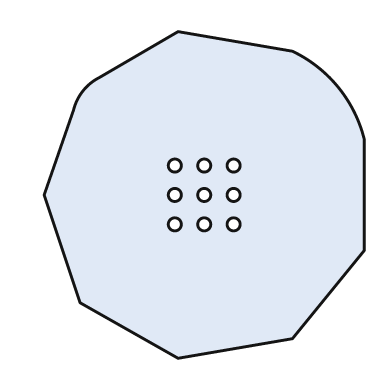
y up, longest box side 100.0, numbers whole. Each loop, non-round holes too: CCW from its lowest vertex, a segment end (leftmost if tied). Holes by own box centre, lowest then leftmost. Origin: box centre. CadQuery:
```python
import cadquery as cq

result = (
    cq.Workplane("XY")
    .moveTo(-8.0, -50.0)
    .lineTo(27.0, -44.0)
    .lineTo(49.0, -17.0)
    .lineTo(49.0, 17.0)
    .threePointArc((41.0, 33.0), (27.0, 44.0))
    .lineTo(-8.0, 50.0)
    .lineTo(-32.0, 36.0)
    .threePointArc((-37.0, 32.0), (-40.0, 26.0))
    .lineTo(-49.0, 0.0)
    .lineTo(-38.0, -33.0)
    .close()
    .moveTo(-9.0, -9.0)
    .circle(2.0)
    .moveTo(0.0, -9.0)
    .circle(2.0)
    .moveTo(9.0, -9.0)
    .circle(2.0)
    .moveTo(-9.0, 0.0)
    .circle(2.0)
    .moveTo(0.0, 0.0)
    .circle(2.0)
    .moveTo(9.0, 0.0)
    .circle(2.0)
    .moveTo(-9.0, 9.0)
    .circle(2.0)
    .moveTo(0.0, 9.0)
    .circle(2.0)
    .moveTo(9.0, 9.0)
    .circle(2.0)
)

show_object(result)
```